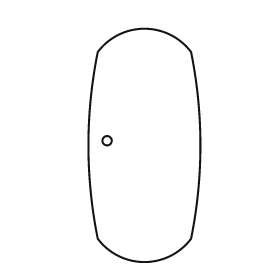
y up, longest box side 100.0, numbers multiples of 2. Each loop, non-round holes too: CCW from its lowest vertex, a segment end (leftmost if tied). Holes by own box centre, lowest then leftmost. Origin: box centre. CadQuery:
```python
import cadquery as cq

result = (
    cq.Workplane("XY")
    .moveTo(-20.0, -40.0)
    .threePointArc((0.0, -50.0), (20.0, -40.0))
    .threePointArc((24.0, 0.0), (20.0, 40.0))
    .threePointArc((0.0, 50.0), (-20.0, 40.0))
    .threePointArc((-24.0, 0.0), (-20.0, -40.0))
    .close()
    .moveTo(-16.0, 2.0)
    .circle(2.0)
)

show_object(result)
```